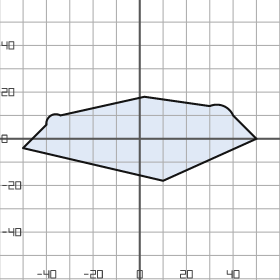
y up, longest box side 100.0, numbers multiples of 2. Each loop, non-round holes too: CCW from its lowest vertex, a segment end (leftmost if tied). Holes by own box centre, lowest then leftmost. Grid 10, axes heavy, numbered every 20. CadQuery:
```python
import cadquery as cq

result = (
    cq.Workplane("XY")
    .moveTo(10.0, -18.0)
    .lineTo(50.0, 0.0)
    .lineTo(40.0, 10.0)
    .threePointArc((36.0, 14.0), (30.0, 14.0))
    .lineTo(2.0, 18.0)
    .lineTo(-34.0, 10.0)
    .threePointArc((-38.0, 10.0), (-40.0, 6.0))
    .lineTo(-50.0, -4.0)
    .close()
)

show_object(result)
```